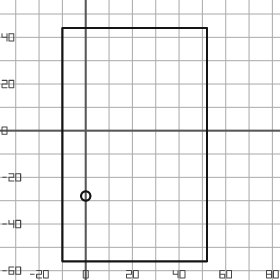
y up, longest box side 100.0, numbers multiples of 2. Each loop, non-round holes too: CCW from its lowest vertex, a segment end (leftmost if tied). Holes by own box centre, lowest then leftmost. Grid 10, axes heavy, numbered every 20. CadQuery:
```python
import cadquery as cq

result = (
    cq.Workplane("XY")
    .moveTo(-10.0, -56.0)
    .lineTo(52.0, -56.0)
    .lineTo(52.0, 44.0)
    .lineTo(-10.0, 44.0)
    .close()
    .moveTo(0.0, -28.0)
    .circle(2.0)
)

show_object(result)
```